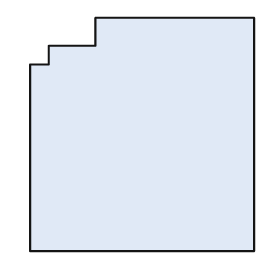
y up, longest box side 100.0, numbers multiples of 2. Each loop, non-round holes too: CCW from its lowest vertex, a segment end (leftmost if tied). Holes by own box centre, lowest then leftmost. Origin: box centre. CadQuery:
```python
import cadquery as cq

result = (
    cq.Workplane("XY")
    .moveTo(-48.0, -50.0)
    .lineTo(48.0, -50.0)
    .lineTo(48.0, 50.0)
    .lineTo(-20.0, 50.0)
    .lineTo(-20.0, 38.0)
    .lineTo(-40.0, 38.0)
    .lineTo(-40.0, 30.0)
    .lineTo(-48.0, 30.0)
    .close()
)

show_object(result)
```